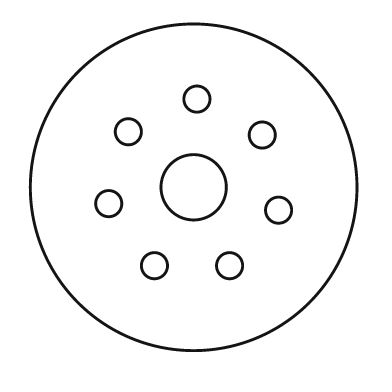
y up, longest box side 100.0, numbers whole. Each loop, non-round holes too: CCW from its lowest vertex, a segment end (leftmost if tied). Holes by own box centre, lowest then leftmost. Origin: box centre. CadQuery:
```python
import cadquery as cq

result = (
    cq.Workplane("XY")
    .moveTo(0.0, 0.0)
    .circle(50.0)
    .moveTo(-12.0, -24.0)
    .circle(4.0)
    .moveTo(11.0, -24.0)
    .circle(4.0)
    .moveTo(26.0, -7.0)
    .circle(4.0)
    .moveTo(-26.0, -5.0)
    .circle(4.0)
    .moveTo(0.0, 0.0)
    .circle(10.0)
    .moveTo(21.0, 16.0)
    .circle(4.0)
    .moveTo(-20.0, 17.0)
    .circle(4.0)
    .moveTo(1.0, 27.0)
    .circle(4.0)
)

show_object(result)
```